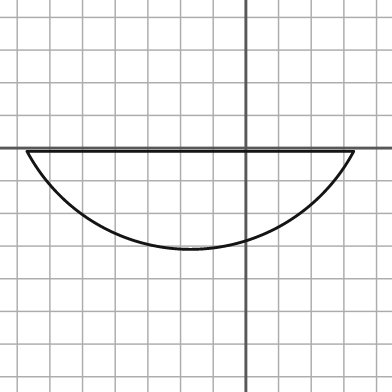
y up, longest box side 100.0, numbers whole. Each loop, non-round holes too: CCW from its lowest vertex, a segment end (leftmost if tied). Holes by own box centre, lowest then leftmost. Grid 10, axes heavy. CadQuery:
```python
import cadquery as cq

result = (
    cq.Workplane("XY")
    .moveTo(-67.0, -1.0)
    .threePointArc((-17.0, -31.0), (33.0, -1.0))
    .close()
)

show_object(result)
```